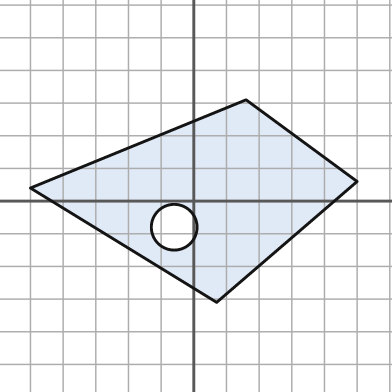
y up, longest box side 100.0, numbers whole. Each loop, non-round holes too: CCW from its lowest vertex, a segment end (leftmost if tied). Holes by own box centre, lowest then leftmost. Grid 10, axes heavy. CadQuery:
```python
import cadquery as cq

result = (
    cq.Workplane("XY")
    .moveTo(7.0, -31.0)
    .lineTo(50.0, 6.0)
    .lineTo(16.0, 31.0)
    .lineTo(-50.0, 4.0)
    .close()
    .moveTo(-6.0, -8.0)
    .circle(7.0)
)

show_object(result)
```